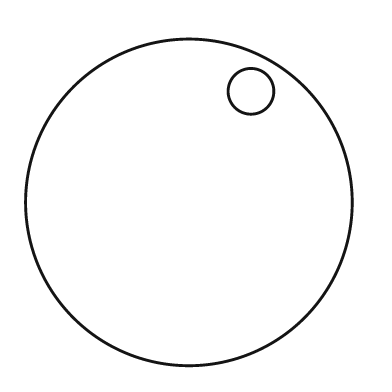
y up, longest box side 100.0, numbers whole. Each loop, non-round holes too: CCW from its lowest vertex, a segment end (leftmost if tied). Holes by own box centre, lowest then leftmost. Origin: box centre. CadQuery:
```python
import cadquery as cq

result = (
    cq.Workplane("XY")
    .moveTo(0.0, 0.0)
    .circle(50.0)
    .moveTo(19.0, 34.0)
    .circle(7.0)
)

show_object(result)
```